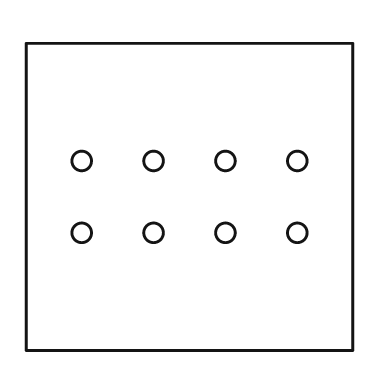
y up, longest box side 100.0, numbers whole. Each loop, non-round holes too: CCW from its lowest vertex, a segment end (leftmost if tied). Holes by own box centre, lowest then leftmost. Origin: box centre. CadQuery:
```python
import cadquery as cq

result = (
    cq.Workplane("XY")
    .moveTo(-50.0, -47.0)
    .lineTo(50.0, -47.0)
    .lineTo(50.0, 47.0)
    .lineTo(-50.0, 47.0)
    .close()
    .moveTo(-33.0, -11.0)
    .circle(3.0)
    .moveTo(-11.0, -11.0)
    .circle(3.0)
    .moveTo(11.0, -11.0)
    .circle(3.0)
    .moveTo(33.0, -11.0)
    .circle(3.0)
    .moveTo(-33.0, 11.0)
    .circle(3.0)
    .moveTo(-11.0, 11.0)
    .circle(3.0)
    .moveTo(11.0, 11.0)
    .circle(3.0)
    .moveTo(33.0, 11.0)
    .circle(3.0)
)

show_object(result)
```